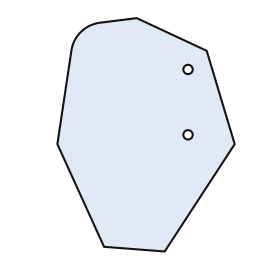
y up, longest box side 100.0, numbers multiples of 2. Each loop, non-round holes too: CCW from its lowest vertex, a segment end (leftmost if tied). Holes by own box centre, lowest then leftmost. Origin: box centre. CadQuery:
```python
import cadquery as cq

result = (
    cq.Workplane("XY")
    .moveTo(8.0, -50.0)
    .lineTo(38.0, -4.0)
    .lineTo(26.0, 36.0)
    .lineTo(-4.0, 50.0)
    .lineTo(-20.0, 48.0)
    .threePointArc((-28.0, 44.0), (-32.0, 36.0))
    .lineTo(-38.0, -4.0)
    .lineTo(-18.0, -48.0)
    .close()
    .moveTo(18.0, 0.0)
    .circle(2.0)
    .moveTo(18.0, 28.0)
    .circle(2.0)
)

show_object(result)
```